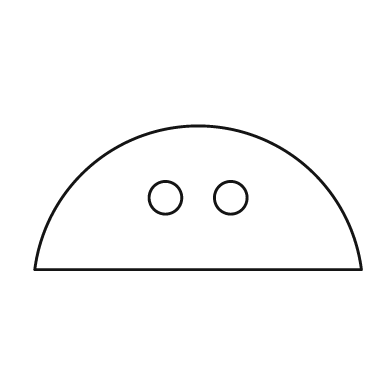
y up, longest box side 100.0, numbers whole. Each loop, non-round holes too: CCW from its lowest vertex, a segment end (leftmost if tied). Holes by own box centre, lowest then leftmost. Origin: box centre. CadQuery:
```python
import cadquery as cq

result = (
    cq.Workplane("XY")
    .moveTo(-50.0, -22.0)
    .lineTo(50.0, -22.0)
    .threePointArc((0.0, 22.0), (-50.0, -22.0))
    .close()
    .moveTo(-10.0, 0.0)
    .circle(5.0)
    .moveTo(10.0, 0.0)
    .circle(5.0)
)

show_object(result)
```